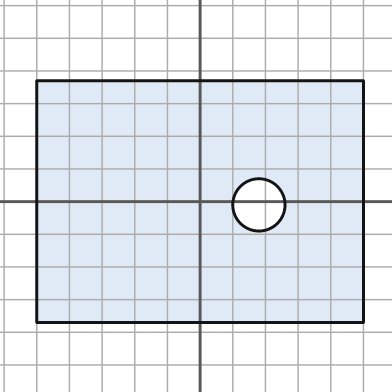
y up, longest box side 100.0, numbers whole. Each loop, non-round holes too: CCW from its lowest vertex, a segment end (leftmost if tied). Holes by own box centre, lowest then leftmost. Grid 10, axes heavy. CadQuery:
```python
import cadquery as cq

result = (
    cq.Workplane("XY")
    .moveTo(-50.0, -37.0)
    .lineTo(50.0, -37.0)
    .lineTo(50.0, 37.0)
    .lineTo(-50.0, 37.0)
    .close()
    .moveTo(18.0, -1.0)
    .circle(8.0)
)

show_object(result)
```